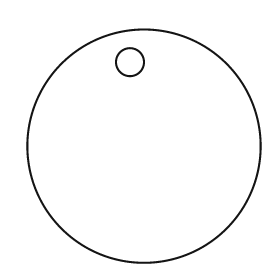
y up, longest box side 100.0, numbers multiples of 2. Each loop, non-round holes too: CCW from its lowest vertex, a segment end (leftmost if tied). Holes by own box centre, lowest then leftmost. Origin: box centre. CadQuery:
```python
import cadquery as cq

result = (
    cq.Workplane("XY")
    .moveTo(0.0, 0.0)
    .circle(50.0)
    .moveTo(-6.0, 36.0)
    .circle(6.0)
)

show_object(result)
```